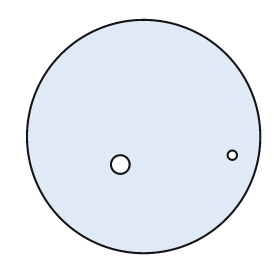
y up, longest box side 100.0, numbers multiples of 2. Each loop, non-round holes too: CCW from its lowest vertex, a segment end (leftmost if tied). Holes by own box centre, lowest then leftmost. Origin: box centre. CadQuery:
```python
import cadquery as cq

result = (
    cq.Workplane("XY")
    .moveTo(0.0, 0.0)
    .circle(50.0)
    .moveTo(-10.0, -12.0)
    .circle(4.0)
    .moveTo(38.0, -8.0)
    .circle(2.0)
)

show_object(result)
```